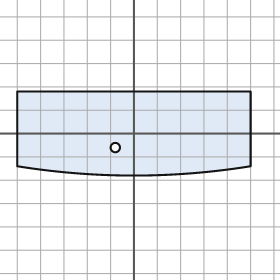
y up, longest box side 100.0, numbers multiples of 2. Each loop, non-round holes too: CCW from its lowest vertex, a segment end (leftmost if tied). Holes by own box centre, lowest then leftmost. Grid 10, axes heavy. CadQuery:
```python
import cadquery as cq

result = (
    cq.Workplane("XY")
    .moveTo(-50.0, -14.0)
    .threePointArc((0.0, -18.0), (50.0, -14.0))
    .lineTo(50.0, 18.0)
    .lineTo(-50.0, 18.0)
    .close()
    .moveTo(-8.0, -6.0)
    .circle(2.0)
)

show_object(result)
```